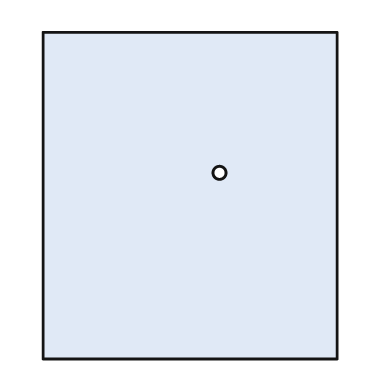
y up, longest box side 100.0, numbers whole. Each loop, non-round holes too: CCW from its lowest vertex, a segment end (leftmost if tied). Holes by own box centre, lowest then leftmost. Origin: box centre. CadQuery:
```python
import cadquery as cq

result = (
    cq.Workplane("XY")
    .moveTo(-45.0, -50.0)
    .lineTo(45.0, -50.0)
    .lineTo(45.0, 50.0)
    .lineTo(-45.0, 50.0)
    .close()
    .moveTo(9.0, 7.0)
    .circle(2.0)
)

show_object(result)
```